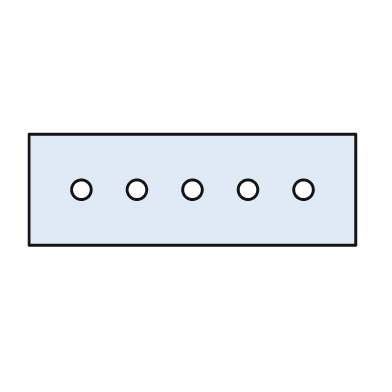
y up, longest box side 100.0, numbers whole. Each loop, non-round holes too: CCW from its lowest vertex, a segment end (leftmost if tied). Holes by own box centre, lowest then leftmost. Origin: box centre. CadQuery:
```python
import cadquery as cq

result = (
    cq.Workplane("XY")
    .moveTo(-50.0, -17.0)
    .lineTo(50.0, -17.0)
    .lineTo(50.0, 17.0)
    .lineTo(-50.0, 17.0)
    .close()
    .moveTo(-34.0, 0.0)
    .circle(3.0)
    .moveTo(-17.0, 0.0)
    .circle(3.0)
    .moveTo(0.0, 0.0)
    .circle(3.0)
    .moveTo(17.0, 0.0)
    .circle(3.0)
    .moveTo(34.0, 0.0)
    .circle(3.0)
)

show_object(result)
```